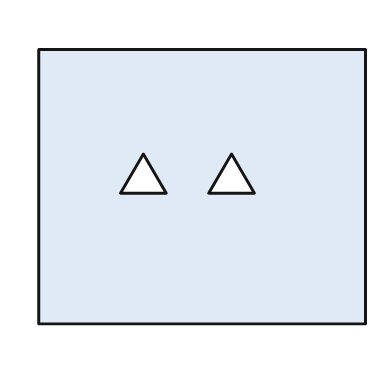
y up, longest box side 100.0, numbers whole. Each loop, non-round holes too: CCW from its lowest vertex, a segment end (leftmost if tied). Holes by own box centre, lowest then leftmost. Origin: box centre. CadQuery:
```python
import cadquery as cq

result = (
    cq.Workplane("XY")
    .moveTo(-50.0, -42.0)
    .lineTo(50.0, -42.0)
    .lineTo(50.0, 42.0)
    .lineTo(-50.0, 42.0)
    .close()
    .moveTo(-25.0, -2.0)
    .lineTo(-11.0, -2.0)
    .lineTo(-18.0, 10.0)
    .close()
    .moveTo(2.0, -2.0)
    .lineTo(16.0, -2.0)
    .lineTo(9.0, 10.0)
    .close()
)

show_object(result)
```